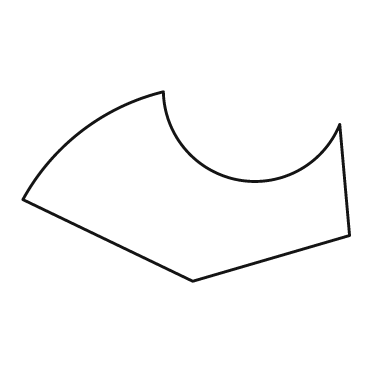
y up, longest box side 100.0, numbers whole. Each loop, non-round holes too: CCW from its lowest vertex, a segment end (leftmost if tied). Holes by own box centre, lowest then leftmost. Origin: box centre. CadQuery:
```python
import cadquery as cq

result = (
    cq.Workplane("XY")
    .moveTo(2.0, -29.0)
    .lineTo(50.0, -15.0)
    .lineTo(47.0, 19.0)
    .threePointArc((16.0, 2.0), (-7.0, 29.0))
    .threePointArc((-32.0, 17.0), (-50.0, -4.0))
    .close()
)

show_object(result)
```